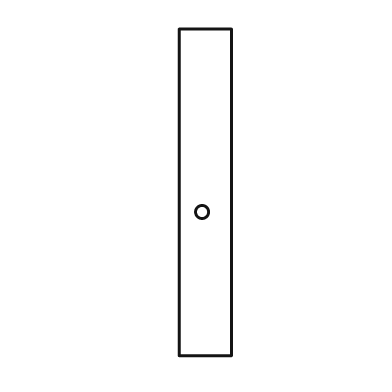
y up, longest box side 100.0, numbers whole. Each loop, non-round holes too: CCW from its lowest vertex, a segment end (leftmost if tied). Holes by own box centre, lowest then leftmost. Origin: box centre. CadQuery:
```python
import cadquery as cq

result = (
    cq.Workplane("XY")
    .moveTo(-8.0, -50.0)
    .lineTo(8.0, -50.0)
    .lineTo(8.0, 50.0)
    .lineTo(-8.0, 50.0)
    .close()
    .moveTo(-1.0, -6.0)
    .circle(2.0)
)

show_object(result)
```